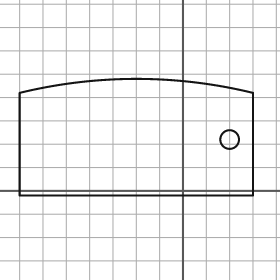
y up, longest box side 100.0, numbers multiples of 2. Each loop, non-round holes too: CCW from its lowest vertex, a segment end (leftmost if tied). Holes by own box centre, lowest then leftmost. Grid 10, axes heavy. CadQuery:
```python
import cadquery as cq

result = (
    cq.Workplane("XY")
    .moveTo(-70.0, -2.0)
    .lineTo(30.0, -2.0)
    .lineTo(30.0, 42.0)
    .threePointArc((-20.0, 48.0), (-70.0, 42.0))
    .close()
    .moveTo(20.0, 22.0)
    .circle(4.0)
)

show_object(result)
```